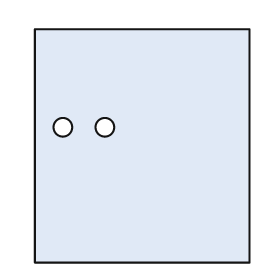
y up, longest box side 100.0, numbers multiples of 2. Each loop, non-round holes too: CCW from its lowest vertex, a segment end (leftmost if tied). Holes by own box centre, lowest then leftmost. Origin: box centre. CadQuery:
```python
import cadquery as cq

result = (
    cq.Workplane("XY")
    .moveTo(-46.0, -50.0)
    .lineTo(46.0, -50.0)
    .lineTo(46.0, 50.0)
    .lineTo(-46.0, 50.0)
    .close()
    .moveTo(-34.0, 8.0)
    .circle(4.0)
    .moveTo(-16.0, 8.0)
    .circle(4.0)
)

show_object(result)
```